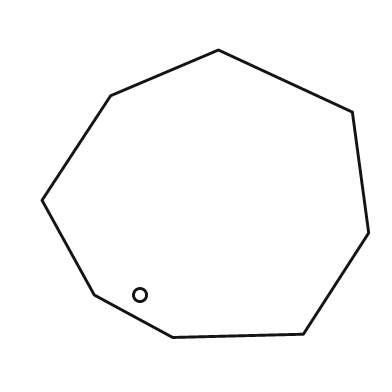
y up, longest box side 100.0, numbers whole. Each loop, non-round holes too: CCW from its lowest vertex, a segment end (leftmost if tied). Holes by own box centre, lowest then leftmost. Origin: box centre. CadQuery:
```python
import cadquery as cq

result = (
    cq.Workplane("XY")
    .moveTo(-10.0, -44.0)
    .lineTo(30.0, -43.0)
    .lineTo(50.0, -12.0)
    .lineTo(45.0, 25.0)
    .lineTo(4.0, 44.0)
    .lineTo(-29.0, 30.0)
    .lineTo(-50.0, -2.0)
    .lineTo(-34.0, -31.0)
    .close()
    .moveTo(-20.0, -31.0)
    .circle(2.0)
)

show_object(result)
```